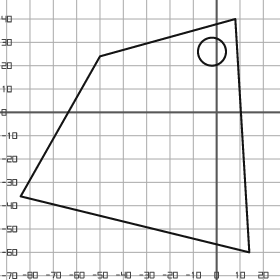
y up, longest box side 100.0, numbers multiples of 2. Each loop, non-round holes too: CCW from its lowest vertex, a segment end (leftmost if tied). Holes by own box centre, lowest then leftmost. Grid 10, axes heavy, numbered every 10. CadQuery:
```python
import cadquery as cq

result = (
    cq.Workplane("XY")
    .moveTo(14.0, -60.0)
    .lineTo(8.0, 40.0)
    .lineTo(-50.0, 24.0)
    .lineTo(-84.0, -36.0)
    .close()
    .moveTo(-2.0, 26.0)
    .circle(6.0)
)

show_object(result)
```